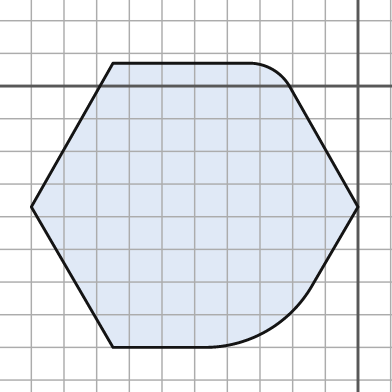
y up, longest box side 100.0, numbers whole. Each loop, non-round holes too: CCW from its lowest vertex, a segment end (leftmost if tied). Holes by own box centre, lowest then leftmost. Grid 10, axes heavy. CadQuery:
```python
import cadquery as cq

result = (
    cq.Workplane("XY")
    .moveTo(-75.0, -80.0)
    .lineTo(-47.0, -80.0)
    .threePointArc((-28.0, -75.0), (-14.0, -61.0))
    .lineTo(0.0, -37.0)
    .lineTo(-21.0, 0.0)
    .threePointArc((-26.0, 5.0), (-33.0, 7.0))
    .lineTo(-75.0, 7.0)
    .lineTo(-100.0, -37.0)
    .close()
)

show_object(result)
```